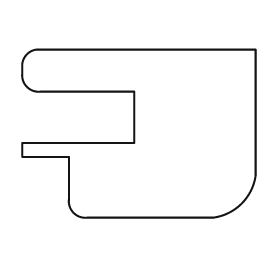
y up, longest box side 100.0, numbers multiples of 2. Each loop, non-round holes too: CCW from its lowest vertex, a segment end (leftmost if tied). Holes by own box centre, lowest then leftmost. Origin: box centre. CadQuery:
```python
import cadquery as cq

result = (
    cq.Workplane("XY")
    .moveTo(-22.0, -36.0)
    .lineTo(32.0, -36.0)
    .threePointArc((44.0, -30.0), (50.0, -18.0))
    .lineTo(50.0, 36.0)
    .lineTo(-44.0, 36.0)
    .threePointArc((-48.0, 34.0), (-50.0, 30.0))
    .lineTo(-50.0, 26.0)
    .threePointArc((-48.0, 20.0), (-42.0, 18.0))
    .lineTo(-2.0, 18.0)
    .lineTo(-2.0, -4.0)
    .lineTo(-50.0, -4.0)
    .lineTo(-50.0, -10.0)
    .lineTo(-30.0, -10.0)
    .lineTo(-30.0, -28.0)
    .threePointArc((-28.0, -34.0), (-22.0, -36.0))
    .close()
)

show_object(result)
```